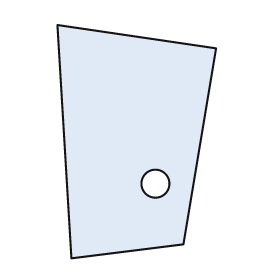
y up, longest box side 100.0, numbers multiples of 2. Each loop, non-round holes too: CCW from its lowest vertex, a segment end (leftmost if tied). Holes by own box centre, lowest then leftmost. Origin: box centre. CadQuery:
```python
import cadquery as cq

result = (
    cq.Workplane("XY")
    .moveTo(-28.0, -50.0)
    .lineTo(20.0, -44.0)
    .lineTo(34.0, 40.0)
    .lineTo(-34.0, 50.0)
    .close()
    .moveTo(8.0, -18.0)
    .circle(6.0)
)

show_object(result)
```